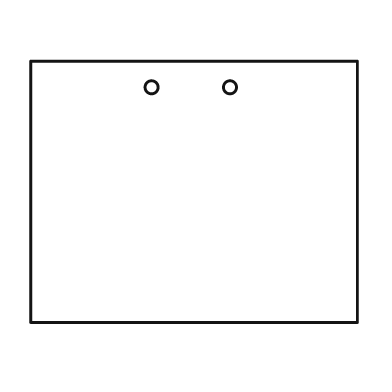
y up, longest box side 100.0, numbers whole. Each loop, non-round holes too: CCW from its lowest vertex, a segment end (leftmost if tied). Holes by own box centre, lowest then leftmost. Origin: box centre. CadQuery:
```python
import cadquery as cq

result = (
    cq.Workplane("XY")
    .moveTo(-50.0, -40.0)
    .lineTo(50.0, -40.0)
    .lineTo(50.0, 40.0)
    .lineTo(-50.0, 40.0)
    .close()
    .moveTo(-13.0, 32.0)
    .circle(2.0)
    .moveTo(11.0, 32.0)
    .circle(2.0)
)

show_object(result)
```